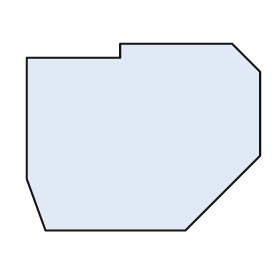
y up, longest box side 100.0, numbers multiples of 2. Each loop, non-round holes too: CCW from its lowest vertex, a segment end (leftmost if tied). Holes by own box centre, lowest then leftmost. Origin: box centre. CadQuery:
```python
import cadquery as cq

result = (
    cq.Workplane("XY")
    .moveTo(-42.0, -40.0)
    .lineTo(18.0, -40.0)
    .lineTo(50.0, -8.0)
    .lineTo(50.0, 28.0)
    .lineTo(38.0, 40.0)
    .lineTo(-10.0, 40.0)
    .lineTo(-10.0, 34.0)
    .lineTo(-50.0, 34.0)
    .lineTo(-50.0, -18.0)
    .close()
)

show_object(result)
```